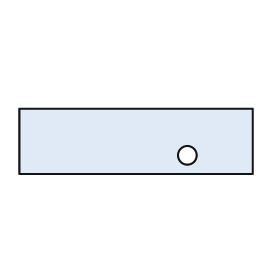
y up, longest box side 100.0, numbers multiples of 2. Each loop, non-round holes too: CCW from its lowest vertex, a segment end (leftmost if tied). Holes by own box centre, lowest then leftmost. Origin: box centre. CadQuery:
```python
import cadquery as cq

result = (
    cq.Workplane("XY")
    .moveTo(-50.0, -14.0)
    .lineTo(50.0, -14.0)
    .lineTo(50.0, 14.0)
    .lineTo(-50.0, 14.0)
    .close()
    .moveTo(22.0, -6.0)
    .circle(4.0)
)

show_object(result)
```